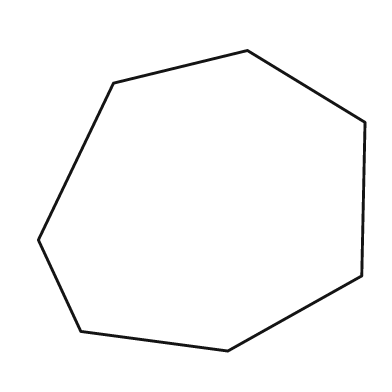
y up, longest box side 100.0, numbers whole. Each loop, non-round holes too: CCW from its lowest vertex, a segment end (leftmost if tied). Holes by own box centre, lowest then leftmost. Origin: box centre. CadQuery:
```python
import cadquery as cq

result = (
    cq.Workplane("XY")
    .moveTo(8.0, -46.0)
    .lineTo(49.0, -23.0)
    .lineTo(50.0, 24.0)
    .lineTo(14.0, 46.0)
    .lineTo(-27.0, 36.0)
    .lineTo(-50.0, -12.0)
    .lineTo(-37.0, -40.0)
    .close()
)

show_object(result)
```